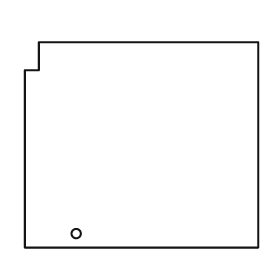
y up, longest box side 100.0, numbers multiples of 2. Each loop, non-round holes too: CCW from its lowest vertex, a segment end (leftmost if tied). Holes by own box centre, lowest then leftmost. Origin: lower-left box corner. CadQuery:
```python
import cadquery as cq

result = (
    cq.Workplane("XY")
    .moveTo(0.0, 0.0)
    .lineTo(100.0, 0.0)
    .lineTo(100.0, 88.0)
    .lineTo(6.0, 88.0)
    .lineTo(6.0, 76.0)
    .lineTo(0.0, 76.0)
    .close()
    .moveTo(22.0, 6.0)
    .circle(2.0)
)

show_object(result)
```